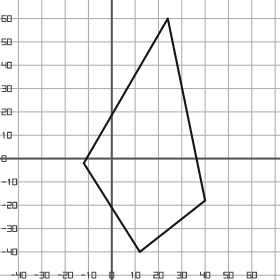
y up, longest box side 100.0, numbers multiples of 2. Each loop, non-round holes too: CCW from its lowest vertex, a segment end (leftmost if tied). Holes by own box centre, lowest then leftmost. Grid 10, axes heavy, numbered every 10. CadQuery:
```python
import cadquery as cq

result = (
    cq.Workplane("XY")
    .moveTo(12.0, -40.0)
    .lineTo(40.0, -18.0)
    .lineTo(24.0, 60.0)
    .lineTo(-12.0, -2.0)
    .close()
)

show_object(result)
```